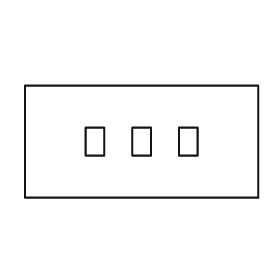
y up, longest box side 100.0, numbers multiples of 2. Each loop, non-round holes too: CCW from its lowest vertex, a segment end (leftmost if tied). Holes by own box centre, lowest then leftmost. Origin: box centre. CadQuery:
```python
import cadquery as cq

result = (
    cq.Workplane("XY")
    .moveTo(-50.0, -24.0)
    .lineTo(50.0, -24.0)
    .lineTo(50.0, 24.0)
    .lineTo(-50.0, 24.0)
    .close()
    .moveTo(-24.0, -6.0)
    .lineTo(-16.0, -6.0)
    .lineTo(-16.0, 6.0)
    .lineTo(-24.0, 6.0)
    .close()
    .moveTo(-4.0, -6.0)
    .lineTo(4.0, -6.0)
    .lineTo(4.0, 6.0)
    .lineTo(-4.0, 6.0)
    .close()
    .moveTo(16.0, -6.0)
    .lineTo(24.0, -6.0)
    .lineTo(24.0, 6.0)
    .lineTo(16.0, 6.0)
    .close()
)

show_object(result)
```